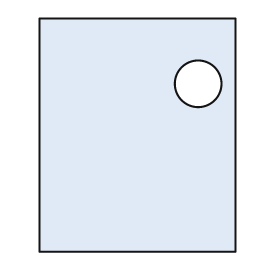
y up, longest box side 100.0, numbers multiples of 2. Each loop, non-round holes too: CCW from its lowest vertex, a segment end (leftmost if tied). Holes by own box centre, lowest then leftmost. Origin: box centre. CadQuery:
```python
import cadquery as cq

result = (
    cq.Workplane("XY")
    .moveTo(-42.0, -50.0)
    .lineTo(42.0, -50.0)
    .lineTo(42.0, 50.0)
    .lineTo(-42.0, 50.0)
    .close()
    .moveTo(26.0, 22.0)
    .circle(10.0)
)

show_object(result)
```